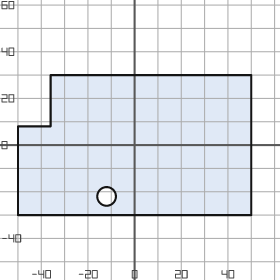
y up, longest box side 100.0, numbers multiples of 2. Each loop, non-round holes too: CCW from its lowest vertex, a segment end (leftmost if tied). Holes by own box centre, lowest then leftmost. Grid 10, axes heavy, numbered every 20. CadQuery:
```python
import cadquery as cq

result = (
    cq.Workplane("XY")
    .moveTo(-50.0, -30.0)
    .lineTo(50.0, -30.0)
    .lineTo(50.0, 30.0)
    .lineTo(-36.0, 30.0)
    .lineTo(-36.0, 8.0)
    .lineTo(-50.0, 8.0)
    .close()
    .moveTo(-12.0, -22.0)
    .circle(4.0)
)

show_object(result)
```